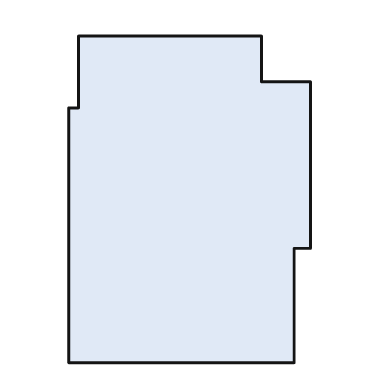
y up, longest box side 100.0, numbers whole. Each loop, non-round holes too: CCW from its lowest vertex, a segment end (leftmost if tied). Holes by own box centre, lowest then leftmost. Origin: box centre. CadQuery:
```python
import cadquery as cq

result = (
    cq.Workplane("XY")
    .moveTo(-37.0, -50.0)
    .lineTo(32.0, -50.0)
    .lineTo(32.0, -15.0)
    .lineTo(37.0, -15.0)
    .lineTo(37.0, 36.0)
    .lineTo(22.0, 36.0)
    .lineTo(22.0, 50.0)
    .lineTo(-34.0, 50.0)
    .lineTo(-34.0, 28.0)
    .lineTo(-37.0, 28.0)
    .close()
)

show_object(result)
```